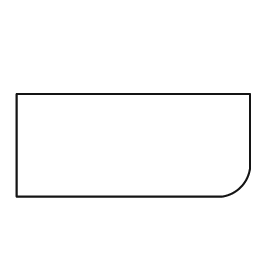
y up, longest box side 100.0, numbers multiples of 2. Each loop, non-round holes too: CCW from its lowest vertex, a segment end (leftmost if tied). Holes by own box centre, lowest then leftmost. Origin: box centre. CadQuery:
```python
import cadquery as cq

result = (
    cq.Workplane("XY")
    .moveTo(-50.0, -22.0)
    .lineTo(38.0, -22.0)
    .threePointArc((46.0, -18.0), (50.0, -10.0))
    .lineTo(50.0, 22.0)
    .lineTo(-50.0, 22.0)
    .close()
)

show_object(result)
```